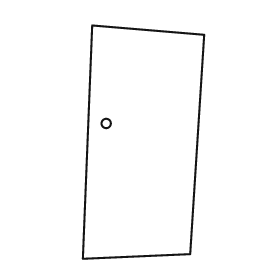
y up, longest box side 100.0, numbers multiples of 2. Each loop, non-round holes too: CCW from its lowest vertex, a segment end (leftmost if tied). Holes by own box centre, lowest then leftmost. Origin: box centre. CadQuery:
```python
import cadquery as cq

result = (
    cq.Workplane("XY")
    .moveTo(-26.0, -50.0)
    .lineTo(20.0, -48.0)
    .lineTo(26.0, 46.0)
    .lineTo(-22.0, 50.0)
    .close()
    .moveTo(-16.0, 8.0)
    .circle(2.0)
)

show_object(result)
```